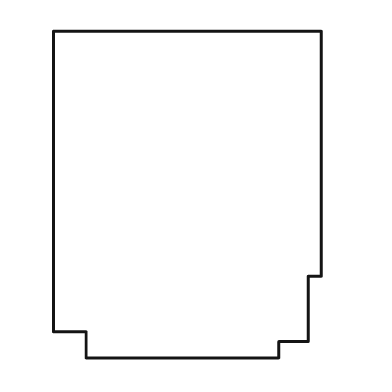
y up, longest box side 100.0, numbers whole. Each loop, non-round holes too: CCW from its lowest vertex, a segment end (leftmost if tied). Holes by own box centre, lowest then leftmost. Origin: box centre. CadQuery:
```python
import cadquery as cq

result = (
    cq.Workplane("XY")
    .moveTo(-31.0, -50.0)
    .lineTo(28.0, -50.0)
    .lineTo(28.0, -45.0)
    .lineTo(37.0, -45.0)
    .lineTo(37.0, -25.0)
    .lineTo(41.0, -25.0)
    .lineTo(41.0, 50.0)
    .lineTo(-41.0, 50.0)
    .lineTo(-41.0, -42.0)
    .lineTo(-31.0, -42.0)
    .close()
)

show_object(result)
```